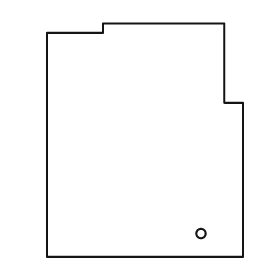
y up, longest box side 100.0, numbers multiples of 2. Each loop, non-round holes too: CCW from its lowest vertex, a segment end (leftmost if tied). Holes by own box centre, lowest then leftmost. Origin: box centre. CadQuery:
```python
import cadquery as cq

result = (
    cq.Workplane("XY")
    .moveTo(-42.0, -50.0)
    .lineTo(42.0, -50.0)
    .lineTo(42.0, 16.0)
    .lineTo(34.0, 16.0)
    .lineTo(34.0, 50.0)
    .lineTo(-18.0, 50.0)
    .lineTo(-18.0, 46.0)
    .lineTo(-42.0, 46.0)
    .close()
    .moveTo(24.0, -40.0)
    .circle(2.0)
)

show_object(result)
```